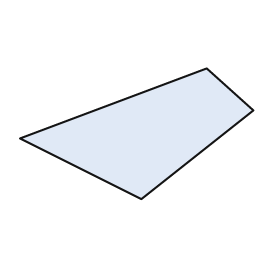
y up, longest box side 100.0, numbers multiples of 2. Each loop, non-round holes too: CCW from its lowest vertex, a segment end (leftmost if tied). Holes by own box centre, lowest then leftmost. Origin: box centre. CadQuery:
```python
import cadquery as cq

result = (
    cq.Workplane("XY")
    .moveTo(2.0, -28.0)
    .lineTo(50.0, 10.0)
    .lineTo(30.0, 28.0)
    .lineTo(-50.0, -2.0)
    .close()
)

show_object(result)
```